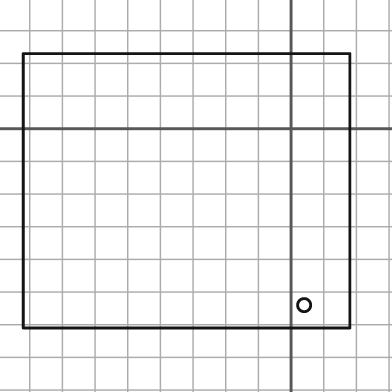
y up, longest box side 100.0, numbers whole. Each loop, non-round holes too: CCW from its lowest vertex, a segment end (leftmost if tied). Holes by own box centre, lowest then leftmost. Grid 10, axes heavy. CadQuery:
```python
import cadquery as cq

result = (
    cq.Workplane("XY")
    .moveTo(-82.0, -61.0)
    .lineTo(18.0, -61.0)
    .lineTo(18.0, 23.0)
    .lineTo(-82.0, 23.0)
    .close()
    .moveTo(4.0, -54.0)
    .circle(2.0)
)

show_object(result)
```